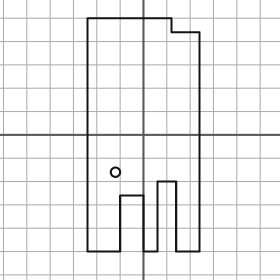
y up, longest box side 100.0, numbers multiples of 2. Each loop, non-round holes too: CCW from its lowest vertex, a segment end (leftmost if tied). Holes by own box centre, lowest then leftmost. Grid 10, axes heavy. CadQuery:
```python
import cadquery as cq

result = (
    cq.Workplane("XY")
    .moveTo(-24.0, -50.0)
    .lineTo(-10.0, -50.0)
    .lineTo(-10.0, -26.0)
    .lineTo(0.0, -26.0)
    .lineTo(0.0, -50.0)
    .lineTo(6.0, -50.0)
    .lineTo(6.0, -20.0)
    .lineTo(14.0, -20.0)
    .lineTo(14.0, -50.0)
    .lineTo(24.0, -50.0)
    .lineTo(24.0, 44.0)
    .lineTo(12.0, 44.0)
    .lineTo(12.0, 50.0)
    .lineTo(-24.0, 50.0)
    .close()
    .moveTo(-12.0, -16.0)
    .circle(2.0)
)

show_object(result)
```